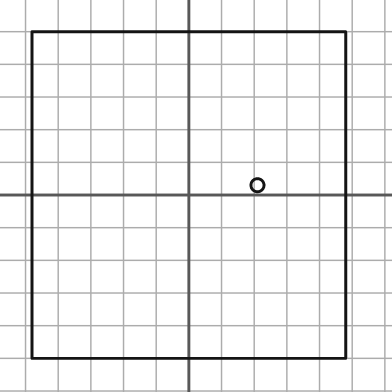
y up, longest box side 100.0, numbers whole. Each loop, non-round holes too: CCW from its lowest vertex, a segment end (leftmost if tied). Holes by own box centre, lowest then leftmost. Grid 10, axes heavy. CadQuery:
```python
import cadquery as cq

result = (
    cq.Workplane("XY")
    .moveTo(-48.0, -50.0)
    .lineTo(48.0, -50.0)
    .lineTo(48.0, 50.0)
    .lineTo(-48.0, 50.0)
    .close()
    .moveTo(21.0, 3.0)
    .circle(2.0)
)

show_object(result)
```